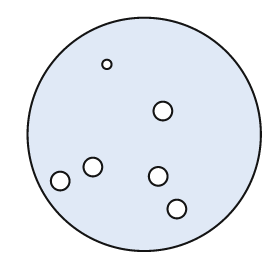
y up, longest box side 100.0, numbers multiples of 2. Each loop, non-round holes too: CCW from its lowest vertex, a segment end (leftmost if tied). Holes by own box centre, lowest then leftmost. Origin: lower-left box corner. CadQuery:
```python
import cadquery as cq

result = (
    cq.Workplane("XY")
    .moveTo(50.0, 50.0)
    .circle(50.0)
    .moveTo(64.0, 18.0)
    .circle(4.0)
    .moveTo(14.0, 30.0)
    .circle(4.0)
    .moveTo(56.0, 32.0)
    .circle(4.0)
    .moveTo(28.0, 36.0)
    .circle(4.0)
    .moveTo(58.0, 60.0)
    .circle(4.0)
    .moveTo(34.0, 80.0)
    .circle(2.0)
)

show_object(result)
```